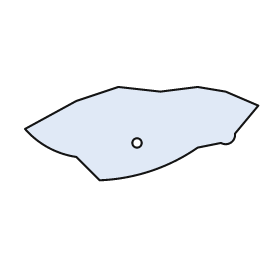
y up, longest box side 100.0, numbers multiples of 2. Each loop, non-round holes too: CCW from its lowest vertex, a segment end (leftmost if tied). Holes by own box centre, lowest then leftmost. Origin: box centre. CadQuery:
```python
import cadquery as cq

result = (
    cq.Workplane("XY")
    .moveTo(-18.0, -20.0)
    .threePointArc((4.0, -16.0), (24.0, -6.0))
    .lineTo(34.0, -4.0)
    .threePointArc((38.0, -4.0), (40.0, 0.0))
    .lineTo(50.0, 12.0)
    .lineTo(36.0, 18.0)
    .lineTo(24.0, 20.0)
    .lineTo(8.0, 18.0)
    .lineTo(-10.0, 20.0)
    .lineTo(-28.0, 14.0)
    .lineTo(-50.0, 2.0)
    .threePointArc((-40.0, -6.0), (-28.0, -10.0))
    .close()
    .moveTo(-2.0, -4.0)
    .circle(2.0)
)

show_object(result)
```